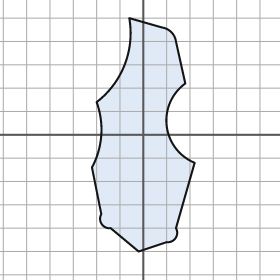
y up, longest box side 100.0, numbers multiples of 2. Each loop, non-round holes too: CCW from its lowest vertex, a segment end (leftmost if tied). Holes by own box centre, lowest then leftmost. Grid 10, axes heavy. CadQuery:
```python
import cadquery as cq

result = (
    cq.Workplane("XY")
    .moveTo(-2.0, -50.0)
    .lineTo(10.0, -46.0)
    .threePointArc((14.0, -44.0), (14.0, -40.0))
    .lineTo(22.0, -12.0)
    .threePointArc((10.0, 4.0), (18.0, 22.0))
    .lineTo(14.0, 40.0)
    .threePointArc((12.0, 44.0), (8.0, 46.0))
    .lineTo(-6.0, 50.0)
    .threePointArc((-8.0, 30.0), (-20.0, 14.0))
    .threePointArc((-18.0, 0.0), (-22.0, -14.0))
    .lineTo(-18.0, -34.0)
    .threePointArc((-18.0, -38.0), (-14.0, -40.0))
    .close()
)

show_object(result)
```